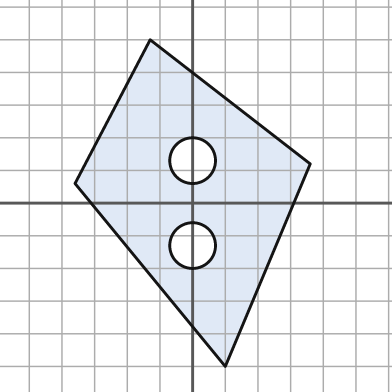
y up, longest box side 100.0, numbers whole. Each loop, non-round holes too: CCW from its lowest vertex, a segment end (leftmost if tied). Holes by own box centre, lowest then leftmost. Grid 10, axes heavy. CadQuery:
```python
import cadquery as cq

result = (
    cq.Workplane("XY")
    .moveTo(10.0, -50.0)
    .lineTo(36.0, 12.0)
    .lineTo(-13.0, 50.0)
    .lineTo(-36.0, 6.0)
    .close()
    .moveTo(0.0, -13.0)
    .circle(7.0)
    .moveTo(0.0, 13.0)
    .circle(7.0)
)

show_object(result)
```